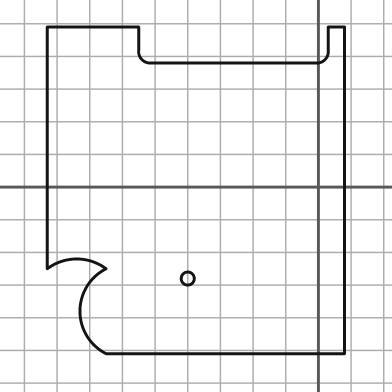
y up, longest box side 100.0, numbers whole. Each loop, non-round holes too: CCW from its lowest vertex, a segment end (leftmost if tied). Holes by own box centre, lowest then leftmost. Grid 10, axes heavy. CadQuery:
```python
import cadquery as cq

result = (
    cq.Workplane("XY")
    .moveTo(-65.0, -51.0)
    .lineTo(8.0, -51.0)
    .lineTo(8.0, 49.0)
    .lineTo(3.0, 49.0)
    .lineTo(3.0, 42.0)
    .threePointArc((2.0, 39.0), (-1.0, 38.0))
    .lineTo(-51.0, 38.0)
    .threePointArc((-54.0, 39.0), (-55.0, 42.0))
    .lineTo(-55.0, 49.0)
    .lineTo(-83.0, 49.0)
    .lineTo(-83.0, -25.0)
    .threePointArc((-74.0, -22.0), (-65.0, -25.0))
    .threePointArc((-73.0, -38.0), (-65.0, -51.0))
    .close()
    .moveTo(-40.0, -28.0)
    .circle(2.0)
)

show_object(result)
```